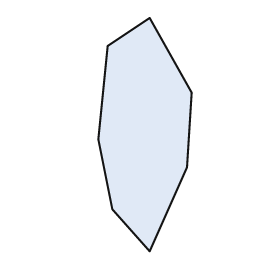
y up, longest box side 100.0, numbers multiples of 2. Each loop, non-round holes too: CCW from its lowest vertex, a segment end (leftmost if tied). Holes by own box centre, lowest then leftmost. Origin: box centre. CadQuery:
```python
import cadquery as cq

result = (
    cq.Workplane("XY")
    .moveTo(2.0, -50.0)
    .lineTo(18.0, -14.0)
    .lineTo(20.0, 18.0)
    .lineTo(2.0, 50.0)
    .lineTo(-16.0, 38.0)
    .lineTo(-20.0, -2.0)
    .lineTo(-14.0, -32.0)
    .close()
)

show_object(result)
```